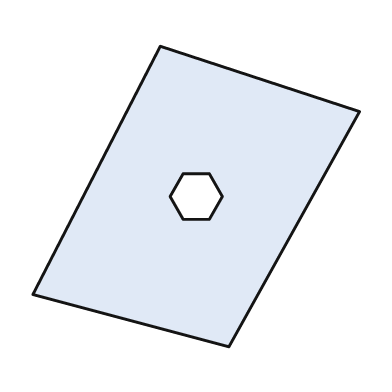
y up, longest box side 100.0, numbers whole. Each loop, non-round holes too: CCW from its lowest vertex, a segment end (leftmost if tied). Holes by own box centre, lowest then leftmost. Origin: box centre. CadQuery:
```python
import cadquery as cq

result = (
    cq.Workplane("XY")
    .moveTo(10.0, -46.0)
    .lineTo(50.0, 26.0)
    .lineTo(-11.0, 46.0)
    .lineTo(-50.0, -30.0)
    .close()
    .moveTo(-4.0, -7.0)
    .lineTo(4.0, -7.0)
    .lineTo(8.0, 0.0)
    .lineTo(4.0, 7.0)
    .lineTo(-4.0, 7.0)
    .lineTo(-8.0, 0.0)
    .close()
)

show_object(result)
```